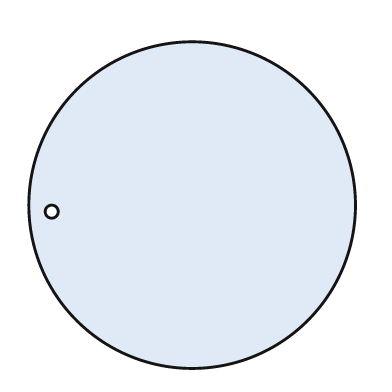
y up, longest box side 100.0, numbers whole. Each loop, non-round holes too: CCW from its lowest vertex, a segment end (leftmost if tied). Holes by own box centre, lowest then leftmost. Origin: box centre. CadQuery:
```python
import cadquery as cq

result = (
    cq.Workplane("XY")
    .moveTo(0.0, 0.0)
    .circle(50.0)
    .moveTo(-43.0, -2.0)
    .circle(2.0)
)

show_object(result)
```